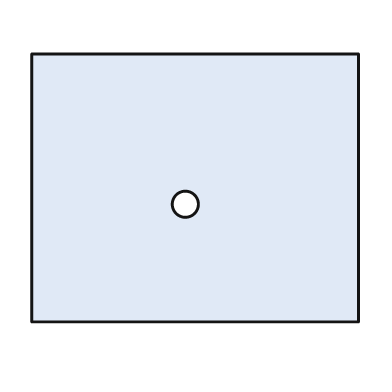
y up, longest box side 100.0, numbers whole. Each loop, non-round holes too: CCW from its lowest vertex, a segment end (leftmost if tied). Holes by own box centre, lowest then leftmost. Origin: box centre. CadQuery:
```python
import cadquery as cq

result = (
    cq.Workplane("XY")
    .moveTo(-50.0, -41.0)
    .lineTo(50.0, -41.0)
    .lineTo(50.0, 41.0)
    .lineTo(-50.0, 41.0)
    .close()
    .moveTo(-3.0, -5.0)
    .circle(4.0)
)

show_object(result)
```